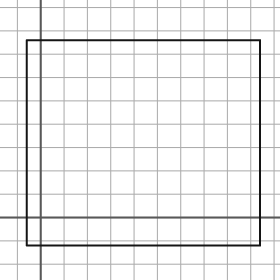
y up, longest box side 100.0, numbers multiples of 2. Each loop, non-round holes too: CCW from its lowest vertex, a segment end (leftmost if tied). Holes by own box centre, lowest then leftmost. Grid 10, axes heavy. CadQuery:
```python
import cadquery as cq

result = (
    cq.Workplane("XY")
    .moveTo(-6.0, -12.0)
    .lineTo(94.0, -12.0)
    .lineTo(94.0, 76.0)
    .lineTo(-6.0, 76.0)
    .close()
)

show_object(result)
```